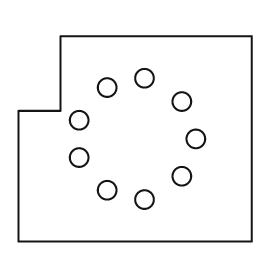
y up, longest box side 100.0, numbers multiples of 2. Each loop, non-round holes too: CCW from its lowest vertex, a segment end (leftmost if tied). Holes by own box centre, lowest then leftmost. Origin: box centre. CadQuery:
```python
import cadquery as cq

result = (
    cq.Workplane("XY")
    .moveTo(-50.0, -44.0)
    .lineTo(50.0, -44.0)
    .lineTo(50.0, 44.0)
    .lineTo(-32.0, 44.0)
    .lineTo(-32.0, 12.0)
    .lineTo(-50.0, 12.0)
    .close()
    .moveTo(4.0, -26.0)
    .circle(4.0)
    .moveTo(-12.0, -22.0)
    .circle(4.0)
    .moveTo(20.0, -16.0)
    .circle(4.0)
    .moveTo(-24.0, -8.0)
    .circle(4.0)
    .moveTo(26.0, 0.0)
    .circle(4.0)
    .moveTo(-24.0, 8.0)
    .circle(4.0)
    .moveTo(20.0, 16.0)
    .circle(4.0)
    .moveTo(-12.0, 22.0)
    .circle(4.0)
    .moveTo(4.0, 26.0)
    .circle(4.0)
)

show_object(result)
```